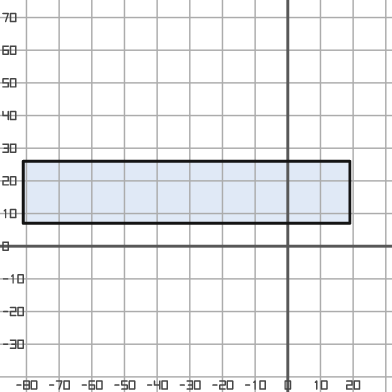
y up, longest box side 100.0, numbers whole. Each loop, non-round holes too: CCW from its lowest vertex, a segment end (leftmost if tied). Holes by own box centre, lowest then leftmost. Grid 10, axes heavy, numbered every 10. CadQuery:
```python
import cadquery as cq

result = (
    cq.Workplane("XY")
    .moveTo(-81.0, 7.0)
    .lineTo(19.0, 7.0)
    .lineTo(19.0, 26.0)
    .lineTo(-81.0, 26.0)
    .close()
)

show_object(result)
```